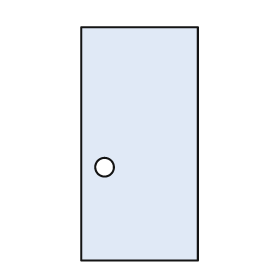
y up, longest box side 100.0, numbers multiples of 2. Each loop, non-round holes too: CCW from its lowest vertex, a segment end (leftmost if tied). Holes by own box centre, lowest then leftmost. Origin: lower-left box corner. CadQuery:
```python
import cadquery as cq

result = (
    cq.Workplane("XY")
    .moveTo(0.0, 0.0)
    .lineTo(50.0, 0.0)
    .lineTo(50.0, 100.0)
    .lineTo(0.0, 100.0)
    .close()
    .moveTo(10.0, 40.0)
    .circle(4.0)
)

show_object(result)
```